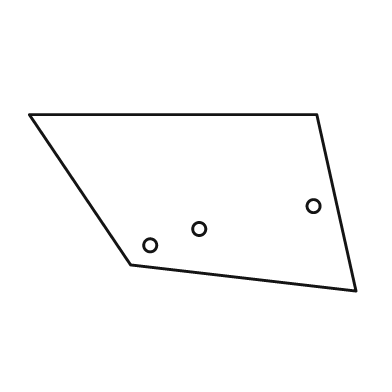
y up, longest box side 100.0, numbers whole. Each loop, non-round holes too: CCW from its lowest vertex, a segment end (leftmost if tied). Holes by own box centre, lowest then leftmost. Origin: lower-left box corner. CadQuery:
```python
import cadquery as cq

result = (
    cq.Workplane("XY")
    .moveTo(100.0, 0.0)
    .lineTo(88.0, 54.0)
    .lineTo(0.0, 54.0)
    .lineTo(31.0, 8.0)
    .close()
    .moveTo(37.0, 14.0)
    .circle(2.0)
    .moveTo(52.0, 19.0)
    .circle(2.0)
    .moveTo(87.0, 26.0)
    .circle(2.0)
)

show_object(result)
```